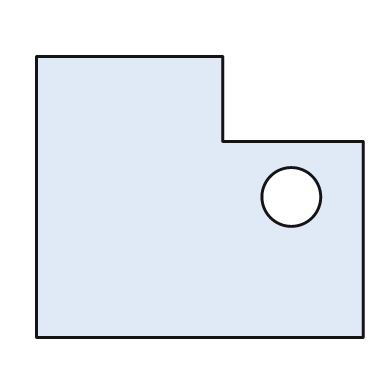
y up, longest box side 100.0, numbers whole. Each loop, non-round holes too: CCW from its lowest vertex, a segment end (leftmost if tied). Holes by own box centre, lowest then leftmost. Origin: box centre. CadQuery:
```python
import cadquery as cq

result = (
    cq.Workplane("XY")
    .moveTo(-50.0, -43.0)
    .lineTo(50.0, -43.0)
    .lineTo(50.0, 17.0)
    .lineTo(7.0, 17.0)
    .lineTo(7.0, 43.0)
    .lineTo(-50.0, 43.0)
    .close()
    .moveTo(28.0, 0.0)
    .circle(9.0)
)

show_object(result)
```